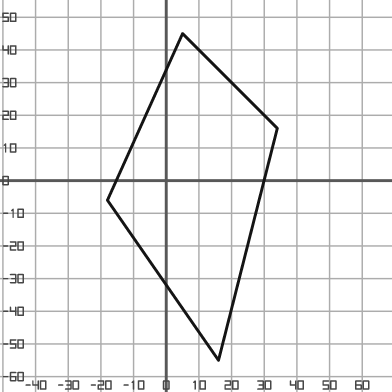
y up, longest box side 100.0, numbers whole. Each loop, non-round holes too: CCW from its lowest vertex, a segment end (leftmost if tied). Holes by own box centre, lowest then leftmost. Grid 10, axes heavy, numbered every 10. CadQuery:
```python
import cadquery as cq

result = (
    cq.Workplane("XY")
    .moveTo(16.0, -55.0)
    .lineTo(34.0, 16.0)
    .lineTo(5.0, 45.0)
    .lineTo(-18.0, -6.0)
    .close()
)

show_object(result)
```